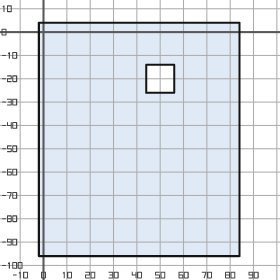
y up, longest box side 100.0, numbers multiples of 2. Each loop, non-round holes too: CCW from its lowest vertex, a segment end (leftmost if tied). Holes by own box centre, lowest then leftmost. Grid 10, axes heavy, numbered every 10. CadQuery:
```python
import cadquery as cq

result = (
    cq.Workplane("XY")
    .moveTo(-2.0, -96.0)
    .lineTo(84.0, -96.0)
    .lineTo(84.0, 4.0)
    .lineTo(-2.0, 4.0)
    .close()
    .moveTo(44.0, -26.0)
    .lineTo(56.0, -26.0)
    .lineTo(56.0, -14.0)
    .lineTo(44.0, -14.0)
    .close()
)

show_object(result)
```